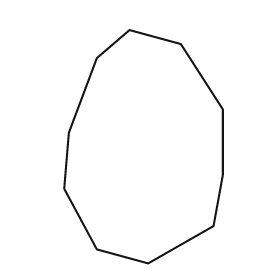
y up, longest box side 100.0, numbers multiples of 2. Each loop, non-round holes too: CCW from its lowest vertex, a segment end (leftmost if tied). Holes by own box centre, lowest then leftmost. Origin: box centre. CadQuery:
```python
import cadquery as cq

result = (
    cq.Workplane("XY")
    .moveTo(2.0, -50.0)
    .lineTo(30.0, -34.0)
    .lineTo(34.0, -12.0)
    .lineTo(34.0, 16.0)
    .lineTo(16.0, 44.0)
    .lineTo(-6.0, 50.0)
    .lineTo(-20.0, 38.0)
    .lineTo(-32.0, 6.0)
    .lineTo(-34.0, -18.0)
    .lineTo(-20.0, -44.0)
    .close()
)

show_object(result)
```